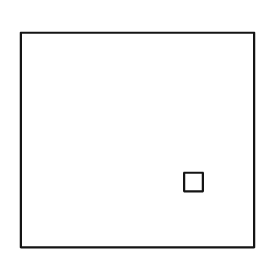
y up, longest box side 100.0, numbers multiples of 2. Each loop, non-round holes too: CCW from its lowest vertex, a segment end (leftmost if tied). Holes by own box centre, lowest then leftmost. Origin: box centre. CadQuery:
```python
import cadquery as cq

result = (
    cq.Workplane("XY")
    .moveTo(-50.0, -46.0)
    .lineTo(50.0, -46.0)
    .lineTo(50.0, 46.0)
    .lineTo(-50.0, 46.0)
    .close()
    .moveTo(20.0, -22.0)
    .lineTo(28.0, -22.0)
    .lineTo(28.0, -14.0)
    .lineTo(20.0, -14.0)
    .close()
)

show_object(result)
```